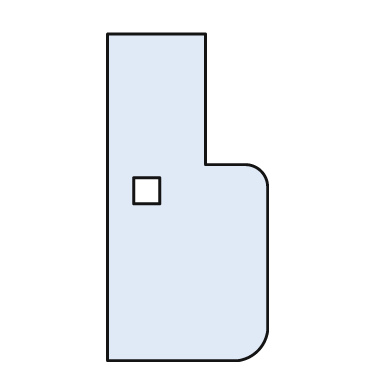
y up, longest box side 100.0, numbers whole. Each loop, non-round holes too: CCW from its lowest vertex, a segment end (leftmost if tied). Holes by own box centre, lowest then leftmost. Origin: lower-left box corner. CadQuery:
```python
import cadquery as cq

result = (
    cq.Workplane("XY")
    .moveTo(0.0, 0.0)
    .lineTo(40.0, 0.0)
    .threePointArc((46.0, 3.0), (49.0, 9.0))
    .lineTo(49.0, 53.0)
    .threePointArc((47.0, 58.0), (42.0, 60.0))
    .lineTo(30.0, 60.0)
    .lineTo(30.0, 100.0)
    .lineTo(0.0, 100.0)
    .close()
    .moveTo(8.0, 48.0)
    .lineTo(16.0, 48.0)
    .lineTo(16.0, 56.0)
    .lineTo(8.0, 56.0)
    .close()
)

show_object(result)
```